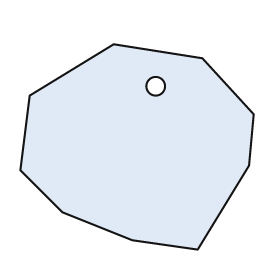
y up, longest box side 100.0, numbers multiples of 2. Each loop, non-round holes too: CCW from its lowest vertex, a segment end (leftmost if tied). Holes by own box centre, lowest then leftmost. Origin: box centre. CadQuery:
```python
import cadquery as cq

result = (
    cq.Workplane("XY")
    .moveTo(26.0, -44.0)
    .lineTo(48.0, -8.0)
    .lineTo(50.0, 14.0)
    .lineTo(28.0, 38.0)
    .lineTo(-10.0, 44.0)
    .lineTo(-46.0, 22.0)
    .lineTo(-50.0, -10.0)
    .lineTo(-32.0, -28.0)
    .lineTo(-2.0, -40.0)
    .close()
    .moveTo(8.0, 26.0)
    .circle(4.0)
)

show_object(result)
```